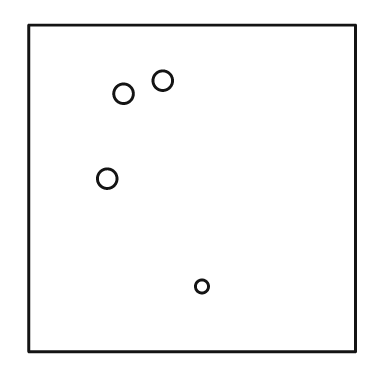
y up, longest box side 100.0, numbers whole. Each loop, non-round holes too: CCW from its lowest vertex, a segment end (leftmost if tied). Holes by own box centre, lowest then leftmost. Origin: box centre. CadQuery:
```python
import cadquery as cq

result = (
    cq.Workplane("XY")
    .moveTo(-50.0, -50.0)
    .lineTo(50.0, -50.0)
    .lineTo(50.0, 50.0)
    .lineTo(-50.0, 50.0)
    .close()
    .moveTo(3.0, -30.0)
    .circle(2.0)
    .moveTo(-26.0, 3.0)
    .circle(3.0)
    .moveTo(-21.0, 29.0)
    .circle(3.0)
    .moveTo(-9.0, 33.0)
    .circle(3.0)
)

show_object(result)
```